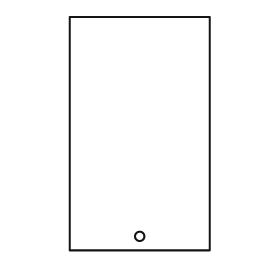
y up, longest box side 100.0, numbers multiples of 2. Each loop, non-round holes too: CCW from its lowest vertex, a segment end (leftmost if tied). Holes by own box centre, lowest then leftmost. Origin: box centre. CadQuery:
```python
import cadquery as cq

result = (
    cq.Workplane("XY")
    .moveTo(-30.0, -50.0)
    .lineTo(30.0, -50.0)
    .lineTo(30.0, 50.0)
    .lineTo(-30.0, 50.0)
    .close()
    .moveTo(0.0, -44.0)
    .circle(2.0)
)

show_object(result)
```